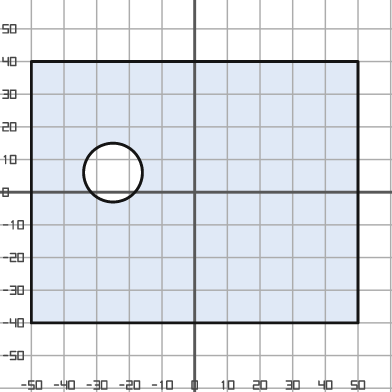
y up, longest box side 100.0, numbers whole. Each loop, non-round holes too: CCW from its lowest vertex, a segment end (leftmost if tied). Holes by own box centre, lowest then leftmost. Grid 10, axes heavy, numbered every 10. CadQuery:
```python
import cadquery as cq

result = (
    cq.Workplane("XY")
    .moveTo(-50.0, -40.0)
    .lineTo(50.0, -40.0)
    .lineTo(50.0, 40.0)
    .lineTo(-50.0, 40.0)
    .close()
    .moveTo(-25.0, 6.0)
    .circle(9.0)
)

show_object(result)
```